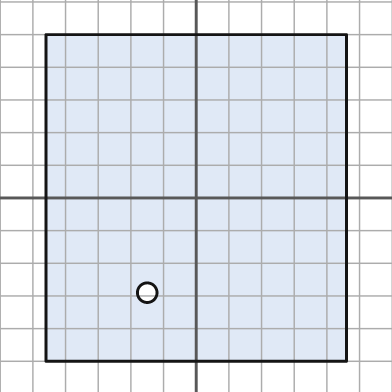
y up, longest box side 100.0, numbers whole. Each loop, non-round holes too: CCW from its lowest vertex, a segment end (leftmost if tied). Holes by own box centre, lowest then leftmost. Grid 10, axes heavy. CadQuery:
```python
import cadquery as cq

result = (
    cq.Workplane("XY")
    .moveTo(-46.0, -50.0)
    .lineTo(46.0, -50.0)
    .lineTo(46.0, 50.0)
    .lineTo(-46.0, 50.0)
    .close()
    .moveTo(-15.0, -29.0)
    .circle(3.0)
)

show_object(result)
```